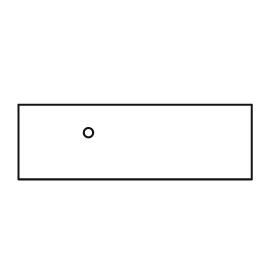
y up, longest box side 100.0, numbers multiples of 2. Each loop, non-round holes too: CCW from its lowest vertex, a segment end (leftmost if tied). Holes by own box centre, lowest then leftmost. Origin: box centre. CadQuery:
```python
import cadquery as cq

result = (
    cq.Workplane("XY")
    .moveTo(-50.0, -16.0)
    .lineTo(50.0, -16.0)
    .lineTo(50.0, 16.0)
    .lineTo(-50.0, 16.0)
    .close()
    .moveTo(-20.0, 4.0)
    .circle(2.0)
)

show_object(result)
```